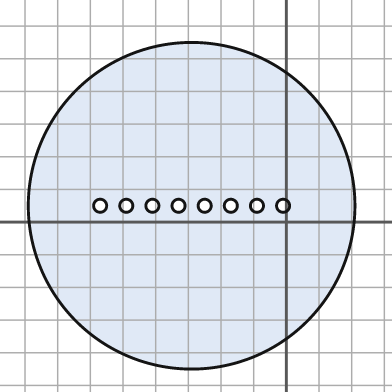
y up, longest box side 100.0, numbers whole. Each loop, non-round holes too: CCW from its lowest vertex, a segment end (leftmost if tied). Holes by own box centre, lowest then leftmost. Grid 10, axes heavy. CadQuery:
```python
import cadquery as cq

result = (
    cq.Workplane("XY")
    .moveTo(-29.0, 5.0)
    .circle(50.0)
    .moveTo(-57.0, 5.0)
    .circle(2.0)
    .moveTo(-49.0, 5.0)
    .circle(2.0)
    .moveTo(-41.0, 5.0)
    .circle(2.0)
    .moveTo(-33.0, 5.0)
    .circle(2.0)
    .moveTo(-25.0, 5.0)
    .circle(2.0)
    .moveTo(-17.0, 5.0)
    .circle(2.0)
    .moveTo(-9.0, 5.0)
    .circle(2.0)
    .moveTo(-1.0, 5.0)
    .circle(2.0)
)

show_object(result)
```